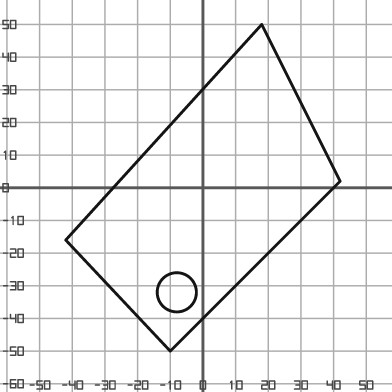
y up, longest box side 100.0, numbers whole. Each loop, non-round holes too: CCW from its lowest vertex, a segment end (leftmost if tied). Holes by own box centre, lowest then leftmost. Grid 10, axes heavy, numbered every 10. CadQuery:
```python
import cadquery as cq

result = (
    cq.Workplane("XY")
    .moveTo(-10.0, -50.0)
    .lineTo(42.0, 2.0)
    .lineTo(18.0, 50.0)
    .lineTo(-42.0, -16.0)
    .close()
    .moveTo(-8.0, -32.0)
    .circle(6.0)
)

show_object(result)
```